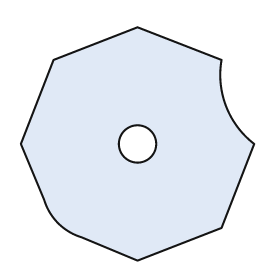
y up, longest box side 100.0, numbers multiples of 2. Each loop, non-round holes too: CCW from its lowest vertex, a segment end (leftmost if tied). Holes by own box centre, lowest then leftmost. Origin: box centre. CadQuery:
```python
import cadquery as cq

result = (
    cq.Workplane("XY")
    .moveTo(0.0, -50.0)
    .lineTo(36.0, -36.0)
    .lineTo(50.0, 0.0)
    .threePointArc((38.0, 16.0), (36.0, 36.0))
    .lineTo(0.0, 50.0)
    .lineTo(-36.0, 36.0)
    .lineTo(-50.0, 0.0)
    .lineTo(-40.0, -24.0)
    .threePointArc((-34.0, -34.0), (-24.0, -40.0))
    .close()
    .moveTo(0.0, 0.0)
    .circle(8.0)
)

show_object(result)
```